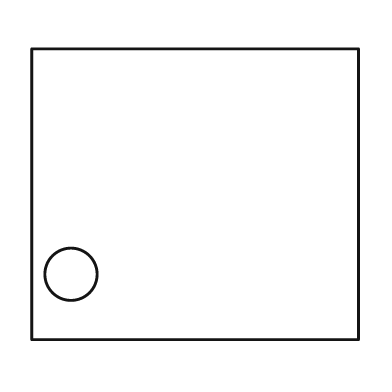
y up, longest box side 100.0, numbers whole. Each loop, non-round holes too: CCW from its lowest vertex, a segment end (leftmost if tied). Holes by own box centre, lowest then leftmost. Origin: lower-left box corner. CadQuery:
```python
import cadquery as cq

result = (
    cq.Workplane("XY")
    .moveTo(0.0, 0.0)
    .lineTo(100.0, 0.0)
    .lineTo(100.0, 89.0)
    .lineTo(0.0, 89.0)
    .close()
    .moveTo(12.0, 20.0)
    .circle(8.0)
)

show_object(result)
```